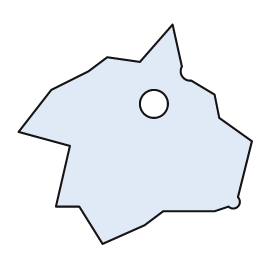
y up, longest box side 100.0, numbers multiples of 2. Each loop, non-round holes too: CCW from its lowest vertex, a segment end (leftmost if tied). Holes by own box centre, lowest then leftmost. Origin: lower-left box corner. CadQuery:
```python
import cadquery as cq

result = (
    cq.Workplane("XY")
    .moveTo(36.0, 0.0)
    .lineTo(54.0, 8.0)
    .lineTo(62.0, 14.0)
    .lineTo(84.0, 14.0)
    .lineTo(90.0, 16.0)
    .threePointArc((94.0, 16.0), (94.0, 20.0))
    .lineTo(100.0, 44.0)
    .lineTo(86.0, 54.0)
    .lineTo(84.0, 64.0)
    .lineTo(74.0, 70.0)
    .threePointArc((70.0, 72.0), (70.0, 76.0))
    .lineTo(66.0, 94.0)
    .lineTo(52.0, 78.0)
    .lineTo(38.0, 80.0)
    .lineTo(30.0, 74.0)
    .lineTo(14.0, 66.0)
    .lineTo(0.0, 48.0)
    .lineTo(22.0, 42.0)
    .lineTo(16.0, 16.0)
    .lineTo(26.0, 16.0)
    .close()
    .moveTo(58.0, 60.0)
    .circle(6.0)
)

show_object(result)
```